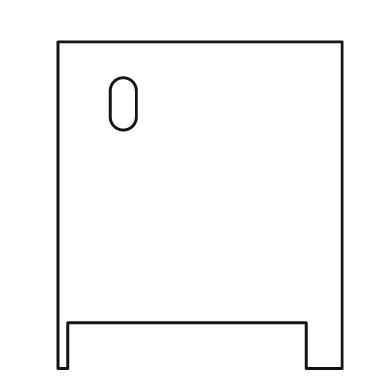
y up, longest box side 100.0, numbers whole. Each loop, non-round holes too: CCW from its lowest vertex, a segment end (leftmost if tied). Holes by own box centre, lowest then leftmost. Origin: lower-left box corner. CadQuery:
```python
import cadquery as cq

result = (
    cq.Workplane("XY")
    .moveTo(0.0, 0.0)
    .lineTo(3.0, 0.0)
    .lineTo(3.0, 14.0)
    .lineTo(76.0, 14.0)
    .lineTo(76.0, 0.0)
    .lineTo(87.0, 0.0)
    .lineTo(87.0, 100.0)
    .lineTo(0.0, 100.0)
    .close()
    .moveTo(16.0, 77.0)
    .threePointArc((20.0, 73.0), (24.0, 77.0))
    .lineTo(24.0, 85.0)
    .threePointArc((20.0, 89.0), (16.0, 85.0))
    .close()
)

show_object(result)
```